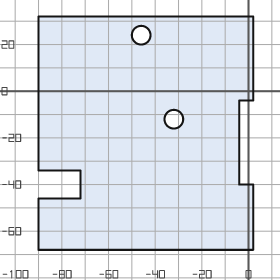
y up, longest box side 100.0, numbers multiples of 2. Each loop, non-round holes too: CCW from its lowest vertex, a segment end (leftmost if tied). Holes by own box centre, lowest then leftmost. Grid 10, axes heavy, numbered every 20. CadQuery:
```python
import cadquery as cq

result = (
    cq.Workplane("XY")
    .moveTo(-90.0, -68.0)
    .lineTo(2.0, -68.0)
    .lineTo(2.0, -40.0)
    .lineTo(-4.0, -40.0)
    .lineTo(-4.0, -4.0)
    .lineTo(2.0, -4.0)
    .lineTo(2.0, 32.0)
    .lineTo(-90.0, 32.0)
    .lineTo(-90.0, -34.0)
    .lineTo(-72.0, -34.0)
    .lineTo(-72.0, -46.0)
    .lineTo(-90.0, -46.0)
    .close()
    .moveTo(-32.0, -12.0)
    .circle(4.0)
    .moveTo(-46.0, 24.0)
    .circle(4.0)
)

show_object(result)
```